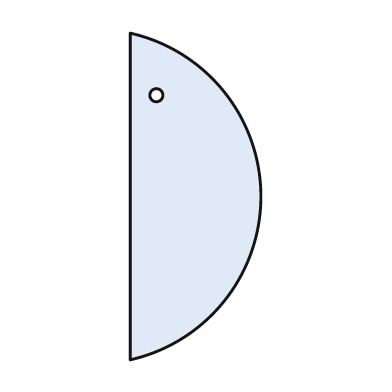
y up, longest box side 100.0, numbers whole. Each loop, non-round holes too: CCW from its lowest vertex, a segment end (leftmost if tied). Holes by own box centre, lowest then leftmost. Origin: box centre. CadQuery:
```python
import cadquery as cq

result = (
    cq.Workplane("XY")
    .moveTo(-20.0, -50.0)
    .threePointArc((20.0, 0.0), (-20.0, 50.0))
    .close()
    .moveTo(-12.0, 31.0)
    .circle(2.0)
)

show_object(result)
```